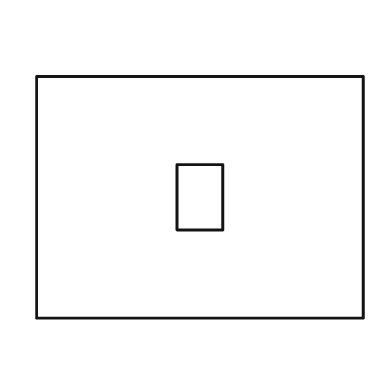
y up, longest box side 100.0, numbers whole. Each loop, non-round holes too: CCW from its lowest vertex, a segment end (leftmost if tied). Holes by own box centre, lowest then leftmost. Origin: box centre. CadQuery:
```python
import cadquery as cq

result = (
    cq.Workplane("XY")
    .moveTo(-50.0, -37.0)
    .lineTo(50.0, -37.0)
    .lineTo(50.0, 37.0)
    .lineTo(-50.0, 37.0)
    .close()
    .moveTo(-7.0, -10.0)
    .lineTo(7.0, -10.0)
    .lineTo(7.0, 10.0)
    .lineTo(-7.0, 10.0)
    .close()
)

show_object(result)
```